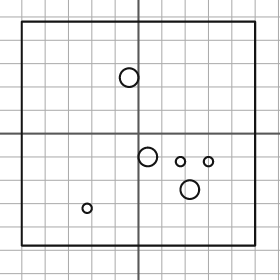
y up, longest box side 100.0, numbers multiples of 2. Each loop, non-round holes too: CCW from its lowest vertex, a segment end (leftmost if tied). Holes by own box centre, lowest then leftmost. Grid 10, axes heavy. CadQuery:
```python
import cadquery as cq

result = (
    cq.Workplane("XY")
    .moveTo(-50.0, -48.0)
    .lineTo(50.0, -48.0)
    .lineTo(50.0, 48.0)
    .lineTo(-50.0, 48.0)
    .close()
    .moveTo(-22.0, -32.0)
    .circle(2.0)
    .moveTo(22.0, -24.0)
    .circle(4.0)
    .moveTo(18.0, -12.0)
    .circle(2.0)
    .moveTo(30.0, -12.0)
    .circle(2.0)
    .moveTo(4.0, -10.0)
    .circle(4.0)
    .moveTo(-4.0, 24.0)
    .circle(4.0)
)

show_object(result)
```